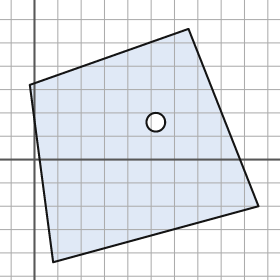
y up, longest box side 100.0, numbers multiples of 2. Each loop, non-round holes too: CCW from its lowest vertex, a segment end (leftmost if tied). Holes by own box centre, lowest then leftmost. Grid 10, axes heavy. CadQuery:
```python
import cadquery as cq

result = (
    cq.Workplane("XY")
    .moveTo(8.0, -44.0)
    .lineTo(96.0, -20.0)
    .lineTo(66.0, 56.0)
    .lineTo(-2.0, 32.0)
    .close()
    .moveTo(52.0, 16.0)
    .circle(4.0)
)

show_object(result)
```